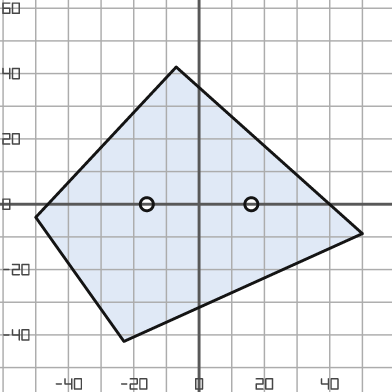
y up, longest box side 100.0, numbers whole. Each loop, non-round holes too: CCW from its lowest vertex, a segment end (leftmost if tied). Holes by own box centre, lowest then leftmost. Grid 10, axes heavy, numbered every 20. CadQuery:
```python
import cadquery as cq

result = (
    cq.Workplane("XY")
    .moveTo(-23.0, -42.0)
    .lineTo(50.0, -9.0)
    .lineTo(-7.0, 42.0)
    .lineTo(-50.0, -4.0)
    .close()
    .moveTo(-16.0, 0.0)
    .circle(2.0)
    .moveTo(16.0, 0.0)
    .circle(2.0)
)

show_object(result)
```